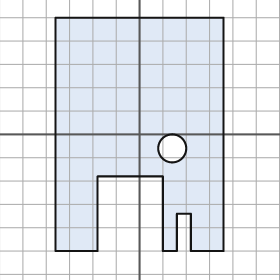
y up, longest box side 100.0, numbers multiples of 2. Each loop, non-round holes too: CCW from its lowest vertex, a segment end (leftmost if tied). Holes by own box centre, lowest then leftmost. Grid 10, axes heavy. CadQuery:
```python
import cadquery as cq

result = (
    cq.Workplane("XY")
    .moveTo(-36.0, -50.0)
    .lineTo(-18.0, -50.0)
    .lineTo(-18.0, -18.0)
    .lineTo(10.0, -18.0)
    .lineTo(10.0, -50.0)
    .lineTo(16.0, -50.0)
    .lineTo(16.0, -34.0)
    .lineTo(22.0, -34.0)
    .lineTo(22.0, -50.0)
    .lineTo(36.0, -50.0)
    .lineTo(36.0, 50.0)
    .lineTo(-36.0, 50.0)
    .close()
    .moveTo(14.0, -6.0)
    .circle(6.0)
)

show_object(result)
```